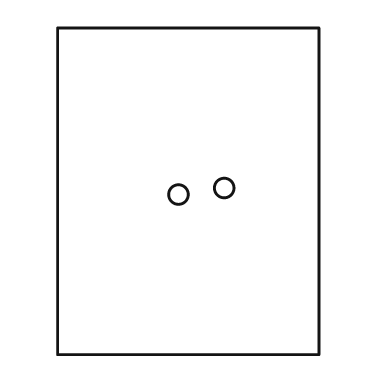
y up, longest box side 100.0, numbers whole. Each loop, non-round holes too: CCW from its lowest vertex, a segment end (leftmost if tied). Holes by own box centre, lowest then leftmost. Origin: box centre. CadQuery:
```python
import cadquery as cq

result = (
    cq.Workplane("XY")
    .moveTo(-40.0, -50.0)
    .lineTo(40.0, -50.0)
    .lineTo(40.0, 50.0)
    .lineTo(-40.0, 50.0)
    .close()
    .moveTo(-3.0, -1.0)
    .circle(3.0)
    .moveTo(11.0, 1.0)
    .circle(3.0)
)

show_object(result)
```